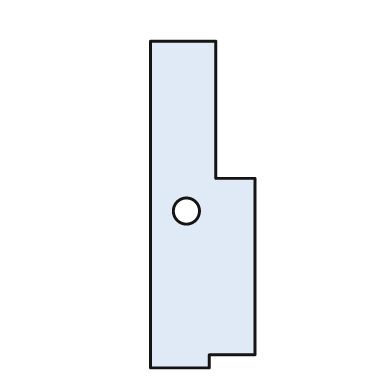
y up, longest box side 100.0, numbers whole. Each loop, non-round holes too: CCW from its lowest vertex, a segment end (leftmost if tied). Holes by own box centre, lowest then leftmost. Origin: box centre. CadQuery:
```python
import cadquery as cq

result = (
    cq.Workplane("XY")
    .moveTo(-16.0, -50.0)
    .lineTo(2.0, -50.0)
    .lineTo(2.0, -46.0)
    .lineTo(16.0, -46.0)
    .lineTo(16.0, 8.0)
    .lineTo(4.0, 8.0)
    .lineTo(4.0, 50.0)
    .lineTo(-16.0, 50.0)
    .close()
    .moveTo(-5.0, -2.0)
    .circle(4.0)
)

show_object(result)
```